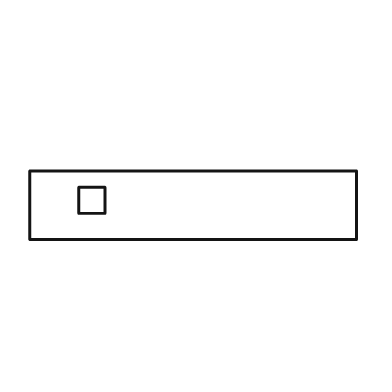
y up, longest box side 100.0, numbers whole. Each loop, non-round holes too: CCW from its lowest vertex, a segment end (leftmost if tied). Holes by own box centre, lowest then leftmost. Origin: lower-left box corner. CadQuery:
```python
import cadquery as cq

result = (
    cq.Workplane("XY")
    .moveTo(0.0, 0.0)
    .lineTo(100.0, 0.0)
    .lineTo(100.0, 21.0)
    .lineTo(0.0, 21.0)
    .close()
    .moveTo(15.0, 8.0)
    .lineTo(23.0, 8.0)
    .lineTo(23.0, 16.0)
    .lineTo(15.0, 16.0)
    .close()
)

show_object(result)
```